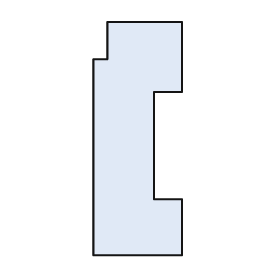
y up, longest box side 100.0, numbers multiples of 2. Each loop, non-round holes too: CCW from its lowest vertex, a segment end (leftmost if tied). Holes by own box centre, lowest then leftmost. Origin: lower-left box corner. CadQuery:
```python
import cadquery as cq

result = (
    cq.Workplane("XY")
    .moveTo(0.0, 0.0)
    .lineTo(38.0, 0.0)
    .lineTo(38.0, 24.0)
    .lineTo(26.0, 24.0)
    .lineTo(26.0, 70.0)
    .lineTo(38.0, 70.0)
    .lineTo(38.0, 100.0)
    .lineTo(6.0, 100.0)
    .lineTo(6.0, 84.0)
    .lineTo(0.0, 84.0)
    .close()
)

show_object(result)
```